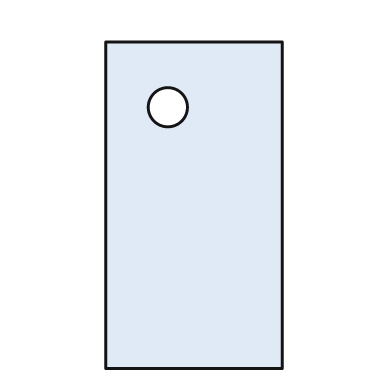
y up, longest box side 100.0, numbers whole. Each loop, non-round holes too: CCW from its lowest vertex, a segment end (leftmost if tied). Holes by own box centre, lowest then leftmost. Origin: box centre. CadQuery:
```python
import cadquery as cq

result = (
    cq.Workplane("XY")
    .moveTo(-27.0, -50.0)
    .lineTo(27.0, -50.0)
    .lineTo(27.0, 50.0)
    .lineTo(-27.0, 50.0)
    .close()
    .moveTo(-8.0, 30.0)
    .circle(6.0)
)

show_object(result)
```